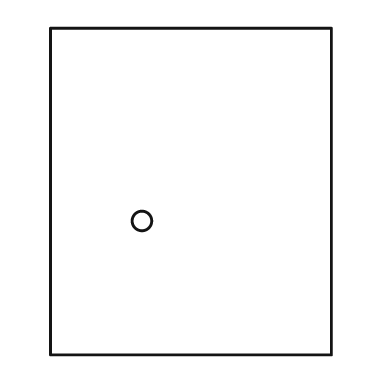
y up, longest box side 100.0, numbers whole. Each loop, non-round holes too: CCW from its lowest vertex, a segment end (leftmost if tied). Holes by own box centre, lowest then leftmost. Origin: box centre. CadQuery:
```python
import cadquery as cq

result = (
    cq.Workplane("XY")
    .moveTo(-43.0, -50.0)
    .lineTo(43.0, -50.0)
    .lineTo(43.0, 50.0)
    .lineTo(-43.0, 50.0)
    .close()
    .moveTo(-15.0, -9.0)
    .circle(3.0)
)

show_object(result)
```